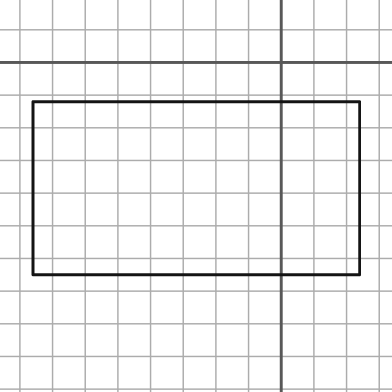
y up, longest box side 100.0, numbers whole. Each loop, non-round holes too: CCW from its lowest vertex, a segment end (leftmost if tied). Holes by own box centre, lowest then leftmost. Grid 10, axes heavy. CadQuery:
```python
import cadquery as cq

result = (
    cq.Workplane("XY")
    .moveTo(-76.0, -65.0)
    .lineTo(24.0, -65.0)
    .lineTo(24.0, -12.0)
    .lineTo(-76.0, -12.0)
    .close()
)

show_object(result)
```